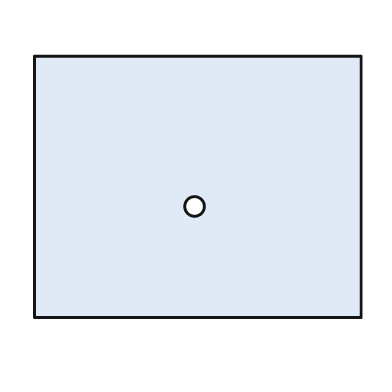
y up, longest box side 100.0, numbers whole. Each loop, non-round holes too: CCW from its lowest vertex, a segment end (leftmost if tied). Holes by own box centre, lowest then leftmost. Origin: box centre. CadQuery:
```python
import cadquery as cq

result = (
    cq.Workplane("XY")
    .moveTo(-50.0, -40.0)
    .lineTo(50.0, -40.0)
    .lineTo(50.0, 40.0)
    .lineTo(-50.0, 40.0)
    .close()
    .moveTo(-1.0, -6.0)
    .circle(3.0)
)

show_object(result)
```